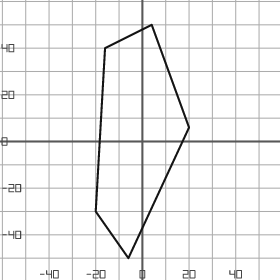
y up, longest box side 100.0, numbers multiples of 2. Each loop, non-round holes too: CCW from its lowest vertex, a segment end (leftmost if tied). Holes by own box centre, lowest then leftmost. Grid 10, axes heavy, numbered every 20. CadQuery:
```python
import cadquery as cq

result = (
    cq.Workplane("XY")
    .moveTo(-6.0, -50.0)
    .lineTo(20.0, 6.0)
    .lineTo(4.0, 50.0)
    .lineTo(-16.0, 40.0)
    .lineTo(-20.0, -30.0)
    .close()
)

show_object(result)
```